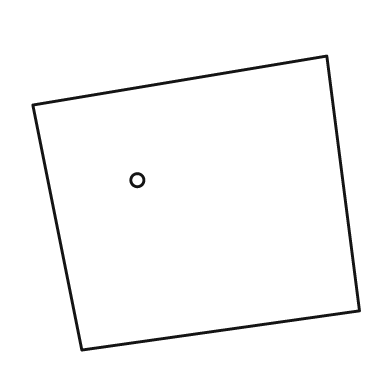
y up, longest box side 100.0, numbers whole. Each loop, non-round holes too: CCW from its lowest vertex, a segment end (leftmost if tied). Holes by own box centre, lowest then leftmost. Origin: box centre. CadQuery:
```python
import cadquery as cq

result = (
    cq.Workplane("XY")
    .moveTo(-35.0, -45.0)
    .lineTo(50.0, -33.0)
    .lineTo(40.0, 45.0)
    .lineTo(-50.0, 30.0)
    .close()
    .moveTo(-18.0, 7.0)
    .circle(2.0)
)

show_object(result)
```